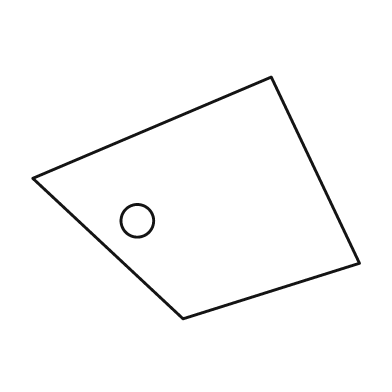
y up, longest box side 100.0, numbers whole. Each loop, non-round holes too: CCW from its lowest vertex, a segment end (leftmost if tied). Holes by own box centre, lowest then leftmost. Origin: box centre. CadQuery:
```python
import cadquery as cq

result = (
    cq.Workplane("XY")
    .moveTo(-4.0, -37.0)
    .lineTo(50.0, -20.0)
    .lineTo(23.0, 37.0)
    .lineTo(-50.0, 6.0)
    .close()
    .moveTo(-18.0, -7.0)
    .circle(5.0)
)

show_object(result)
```